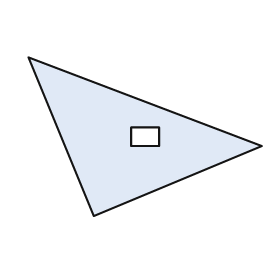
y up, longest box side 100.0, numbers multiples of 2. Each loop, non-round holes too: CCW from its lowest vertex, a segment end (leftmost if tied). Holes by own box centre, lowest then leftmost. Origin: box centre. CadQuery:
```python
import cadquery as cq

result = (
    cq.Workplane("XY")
    .moveTo(-22.0, -34.0)
    .lineTo(50.0, -4.0)
    .lineTo(-50.0, 34.0)
    .close()
    .moveTo(-6.0, -4.0)
    .lineTo(6.0, -4.0)
    .lineTo(6.0, 4.0)
    .lineTo(-6.0, 4.0)
    .close()
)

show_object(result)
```